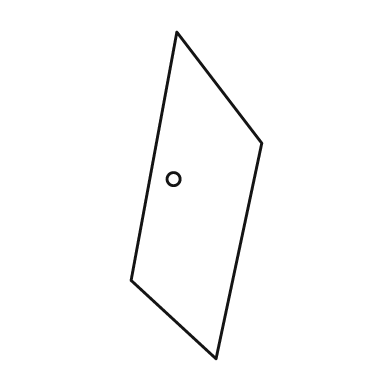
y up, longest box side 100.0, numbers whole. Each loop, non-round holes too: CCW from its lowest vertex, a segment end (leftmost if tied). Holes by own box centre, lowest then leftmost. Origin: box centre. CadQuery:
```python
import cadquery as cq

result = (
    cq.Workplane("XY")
    .moveTo(6.0, -50.0)
    .lineTo(20.0, 16.0)
    .lineTo(-6.0, 50.0)
    .lineTo(-20.0, -26.0)
    .close()
    .moveTo(-7.0, 5.0)
    .circle(2.0)
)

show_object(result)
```